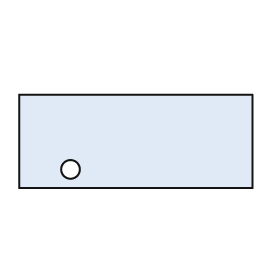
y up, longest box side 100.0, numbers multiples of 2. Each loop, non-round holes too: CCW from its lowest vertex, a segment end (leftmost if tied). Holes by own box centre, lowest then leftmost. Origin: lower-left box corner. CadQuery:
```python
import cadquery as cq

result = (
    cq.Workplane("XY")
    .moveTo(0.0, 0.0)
    .lineTo(100.0, 0.0)
    .lineTo(100.0, 40.0)
    .lineTo(0.0, 40.0)
    .close()
    .moveTo(22.0, 8.0)
    .circle(4.0)
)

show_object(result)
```